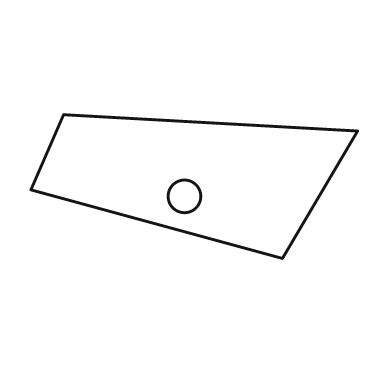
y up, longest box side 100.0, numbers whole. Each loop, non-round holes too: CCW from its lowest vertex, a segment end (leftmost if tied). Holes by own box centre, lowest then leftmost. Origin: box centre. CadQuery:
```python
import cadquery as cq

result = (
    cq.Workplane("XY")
    .moveTo(27.0, -22.0)
    .lineTo(50.0, 17.0)
    .lineTo(-40.0, 22.0)
    .lineTo(-50.0, -1.0)
    .close()
    .moveTo(-3.0, -3.0)
    .circle(5.0)
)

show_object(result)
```